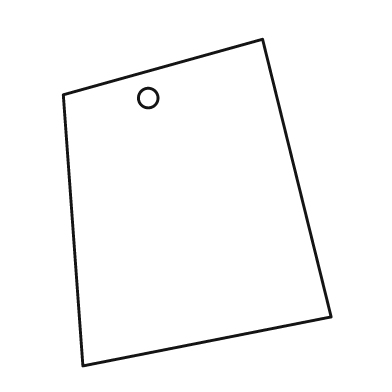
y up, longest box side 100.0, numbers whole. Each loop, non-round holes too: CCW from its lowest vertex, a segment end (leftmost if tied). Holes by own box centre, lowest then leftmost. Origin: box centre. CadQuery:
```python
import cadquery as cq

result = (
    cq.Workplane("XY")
    .moveTo(-35.0, -50.0)
    .lineTo(41.0, -35.0)
    .lineTo(20.0, 50.0)
    .lineTo(-41.0, 33.0)
    .close()
    .moveTo(-15.0, 32.0)
    .circle(3.0)
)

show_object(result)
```